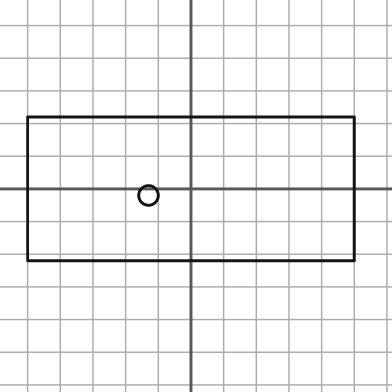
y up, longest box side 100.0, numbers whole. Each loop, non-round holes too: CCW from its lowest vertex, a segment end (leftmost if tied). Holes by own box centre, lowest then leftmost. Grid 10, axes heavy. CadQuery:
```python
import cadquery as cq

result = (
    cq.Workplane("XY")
    .moveTo(-50.0, -22.0)
    .lineTo(50.0, -22.0)
    .lineTo(50.0, 22.0)
    .lineTo(-50.0, 22.0)
    .close()
    .moveTo(-13.0, -2.0)
    .circle(3.0)
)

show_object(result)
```